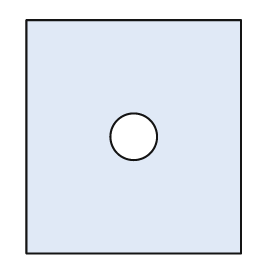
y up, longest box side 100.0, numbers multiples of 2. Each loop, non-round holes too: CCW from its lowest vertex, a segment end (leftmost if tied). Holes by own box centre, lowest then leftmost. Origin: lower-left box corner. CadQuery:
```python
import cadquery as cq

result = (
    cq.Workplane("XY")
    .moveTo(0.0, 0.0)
    .lineTo(92.0, 0.0)
    .lineTo(92.0, 100.0)
    .lineTo(0.0, 100.0)
    .close()
    .moveTo(46.0, 50.0)
    .circle(10.0)
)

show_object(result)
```